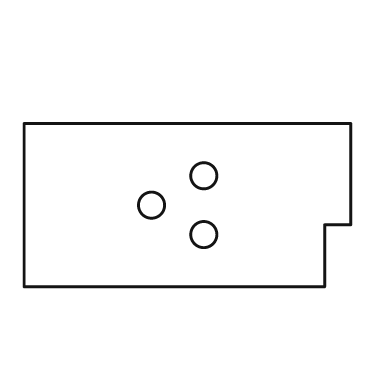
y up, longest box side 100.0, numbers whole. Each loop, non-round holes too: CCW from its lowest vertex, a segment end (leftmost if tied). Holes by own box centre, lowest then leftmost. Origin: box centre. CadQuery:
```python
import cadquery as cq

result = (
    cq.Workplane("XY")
    .moveTo(-50.0, -25.0)
    .lineTo(42.0, -25.0)
    .lineTo(42.0, -6.0)
    .lineTo(50.0, -6.0)
    .lineTo(50.0, 25.0)
    .lineTo(-50.0, 25.0)
    .close()
    .moveTo(5.0, -9.0)
    .circle(4.0)
    .moveTo(-11.0, 0.0)
    .circle(4.0)
    .moveTo(5.0, 9.0)
    .circle(4.0)
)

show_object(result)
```